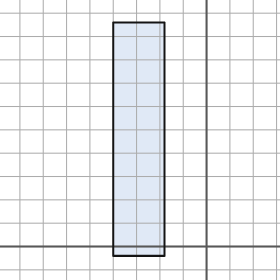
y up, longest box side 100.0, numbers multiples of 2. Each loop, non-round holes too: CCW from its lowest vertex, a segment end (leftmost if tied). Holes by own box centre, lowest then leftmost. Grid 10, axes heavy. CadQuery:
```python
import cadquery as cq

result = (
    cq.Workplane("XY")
    .moveTo(-40.0, -4.0)
    .lineTo(-18.0, -4.0)
    .lineTo(-18.0, 96.0)
    .lineTo(-40.0, 96.0)
    .close()
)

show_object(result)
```